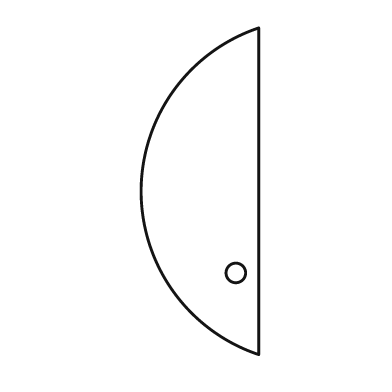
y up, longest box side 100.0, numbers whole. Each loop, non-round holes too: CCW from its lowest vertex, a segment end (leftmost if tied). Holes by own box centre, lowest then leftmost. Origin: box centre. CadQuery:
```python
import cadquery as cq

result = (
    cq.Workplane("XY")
    .moveTo(18.0, -50.0)
    .lineTo(18.0, 50.0)
    .threePointArc((-18.0, 0.0), (18.0, -50.0))
    .close()
    .moveTo(11.0, -25.0)
    .circle(3.0)
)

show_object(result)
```